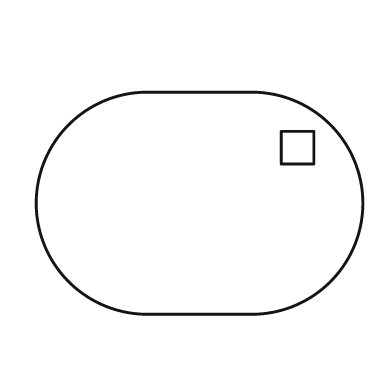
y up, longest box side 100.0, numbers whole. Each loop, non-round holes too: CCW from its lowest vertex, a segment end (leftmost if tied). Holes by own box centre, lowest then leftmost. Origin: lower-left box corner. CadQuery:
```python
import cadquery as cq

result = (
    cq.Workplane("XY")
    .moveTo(34.0, 0.0)
    .lineTo(66.0, 0.0)
    .threePointArc((100.0, 34.0), (66.0, 68.0))
    .lineTo(34.0, 68.0)
    .threePointArc((0.0, 34.0), (34.0, 0.0))
    .close()
    .moveTo(75.0, 46.0)
    .lineTo(85.0, 46.0)
    .lineTo(85.0, 56.0)
    .lineTo(75.0, 56.0)
    .close()
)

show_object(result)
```